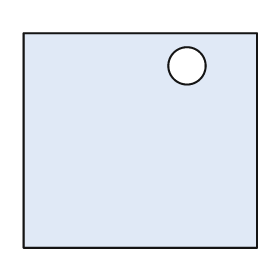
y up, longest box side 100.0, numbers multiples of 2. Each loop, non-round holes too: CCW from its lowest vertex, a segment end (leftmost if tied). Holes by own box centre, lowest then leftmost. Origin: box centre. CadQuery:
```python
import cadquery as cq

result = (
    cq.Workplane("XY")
    .moveTo(-50.0, -46.0)
    .lineTo(50.0, -46.0)
    .lineTo(50.0, 46.0)
    .lineTo(-50.0, 46.0)
    .close()
    .moveTo(20.0, 32.0)
    .circle(8.0)
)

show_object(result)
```